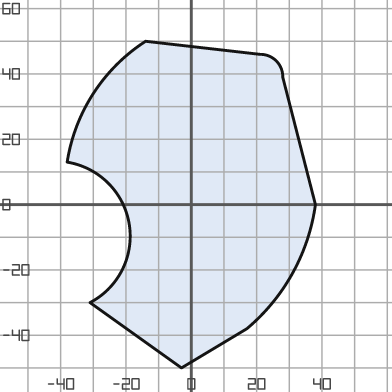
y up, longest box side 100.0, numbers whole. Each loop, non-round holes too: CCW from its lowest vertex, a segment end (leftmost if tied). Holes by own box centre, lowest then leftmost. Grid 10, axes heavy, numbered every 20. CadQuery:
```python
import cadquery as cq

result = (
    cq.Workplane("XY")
    .moveTo(-3.0, -50.0)
    .lineTo(17.0, -38.0)
    .threePointArc((31.0, -21.0), (38.0, 0.0))
    .lineTo(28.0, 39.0)
    .threePointArc((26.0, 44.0), (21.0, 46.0))
    .lineTo(-14.0, 50.0)
    .threePointArc((-30.0, 34.0), (-38.0, 13.0))
    .threePointArc((-19.0, -6.0), (-31.0, -30.0))
    .close()
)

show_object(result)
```